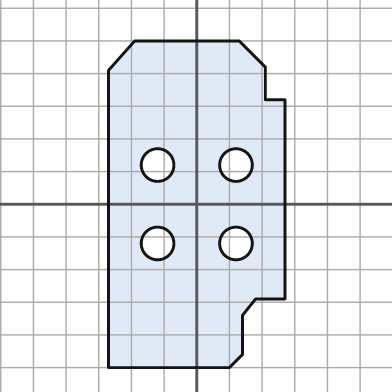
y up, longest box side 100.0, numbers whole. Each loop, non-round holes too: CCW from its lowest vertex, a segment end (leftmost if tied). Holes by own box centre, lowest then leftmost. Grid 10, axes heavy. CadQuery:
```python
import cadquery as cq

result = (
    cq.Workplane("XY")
    .moveTo(-27.0, -50.0)
    .lineTo(10.0, -50.0)
    .lineTo(14.0, -46.0)
    .lineTo(14.0, -34.0)
    .lineTo(18.0, -29.0)
    .lineTo(27.0, -29.0)
    .lineTo(27.0, 32.0)
    .lineTo(21.0, 32.0)
    .lineTo(21.0, 42.0)
    .lineTo(13.0, 50.0)
    .lineTo(-19.0, 50.0)
    .lineTo(-27.0, 41.0)
    .close()
    .moveTo(-12.0, -12.0)
    .circle(5.0)
    .moveTo(12.0, -12.0)
    .circle(5.0)
    .moveTo(-12.0, 12.0)
    .circle(5.0)
    .moveTo(12.0, 12.0)
    .circle(5.0)
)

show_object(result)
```